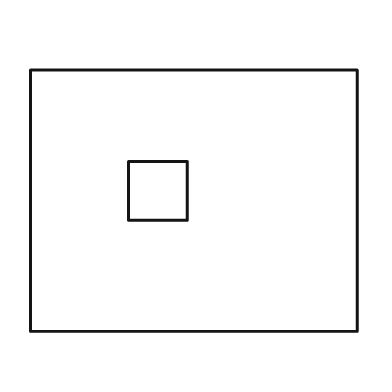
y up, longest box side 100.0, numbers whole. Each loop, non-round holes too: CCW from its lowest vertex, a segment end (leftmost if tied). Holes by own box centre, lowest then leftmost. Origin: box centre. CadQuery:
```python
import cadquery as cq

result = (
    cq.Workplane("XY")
    .moveTo(-50.0, -40.0)
    .lineTo(50.0, -40.0)
    .lineTo(50.0, 40.0)
    .lineTo(-50.0, 40.0)
    .close()
    .moveTo(-20.0, -6.0)
    .lineTo(-2.0, -6.0)
    .lineTo(-2.0, 12.0)
    .lineTo(-20.0, 12.0)
    .close()
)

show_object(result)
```